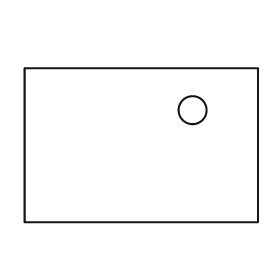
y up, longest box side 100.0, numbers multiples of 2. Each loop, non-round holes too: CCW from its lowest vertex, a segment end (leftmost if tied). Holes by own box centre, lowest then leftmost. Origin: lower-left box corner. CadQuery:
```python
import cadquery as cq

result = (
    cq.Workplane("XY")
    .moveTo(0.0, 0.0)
    .lineTo(100.0, 0.0)
    .lineTo(100.0, 66.0)
    .lineTo(0.0, 66.0)
    .close()
    .moveTo(72.0, 48.0)
    .circle(6.0)
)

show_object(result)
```